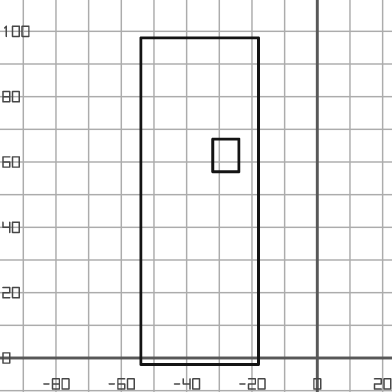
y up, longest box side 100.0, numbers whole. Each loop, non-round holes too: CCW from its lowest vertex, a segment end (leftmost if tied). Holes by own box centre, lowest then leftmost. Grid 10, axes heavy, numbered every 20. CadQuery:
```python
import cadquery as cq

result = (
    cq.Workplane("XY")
    .moveTo(-54.0, -2.0)
    .lineTo(-18.0, -2.0)
    .lineTo(-18.0, 98.0)
    .lineTo(-54.0, 98.0)
    .close()
    .moveTo(-32.0, 57.0)
    .lineTo(-24.0, 57.0)
    .lineTo(-24.0, 67.0)
    .lineTo(-32.0, 67.0)
    .close()
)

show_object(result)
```